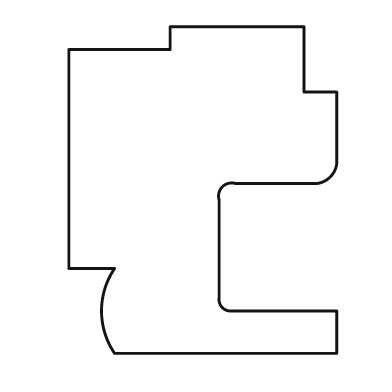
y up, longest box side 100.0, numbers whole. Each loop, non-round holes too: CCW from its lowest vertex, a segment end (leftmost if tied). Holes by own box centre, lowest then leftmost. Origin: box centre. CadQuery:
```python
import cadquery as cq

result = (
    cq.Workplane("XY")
    .moveTo(-27.0, -50.0)
    .lineTo(41.0, -50.0)
    .lineTo(41.0, -37.0)
    .lineTo(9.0, -37.0)
    .threePointArc((6.0, -36.0), (5.0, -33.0))
    .lineTo(5.0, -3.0)
    .threePointArc((6.0, 1.0), (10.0, 2.0))
    .lineTo(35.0, 2.0)
    .threePointArc((39.0, 4.0), (41.0, 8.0))
    .lineTo(41.0, 30.0)
    .lineTo(31.0, 30.0)
    .lineTo(31.0, 50.0)
    .lineTo(-10.0, 50.0)
    .lineTo(-10.0, 43.0)
    .lineTo(-41.0, 43.0)
    .lineTo(-41.0, -24.0)
    .lineTo(-27.0, -24.0)
    .threePointArc((-31.0, -37.0), (-27.0, -50.0))
    .close()
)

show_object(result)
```